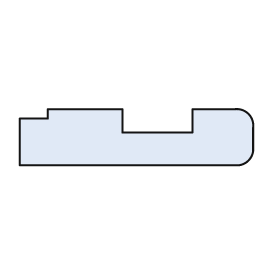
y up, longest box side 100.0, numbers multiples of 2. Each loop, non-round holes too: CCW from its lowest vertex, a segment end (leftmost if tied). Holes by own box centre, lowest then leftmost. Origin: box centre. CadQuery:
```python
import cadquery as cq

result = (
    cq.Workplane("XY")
    .moveTo(-50.0, -12.0)
    .lineTo(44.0, -12.0)
    .threePointArc((48.0, -10.0), (50.0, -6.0))
    .lineTo(50.0, 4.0)
    .threePointArc((48.0, 10.0), (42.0, 12.0))
    .lineTo(24.0, 12.0)
    .lineTo(24.0, 2.0)
    .lineTo(-6.0, 2.0)
    .lineTo(-6.0, 12.0)
    .lineTo(-38.0, 12.0)
    .lineTo(-38.0, 8.0)
    .lineTo(-50.0, 8.0)
    .close()
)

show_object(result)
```